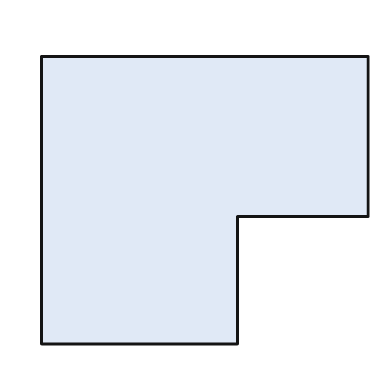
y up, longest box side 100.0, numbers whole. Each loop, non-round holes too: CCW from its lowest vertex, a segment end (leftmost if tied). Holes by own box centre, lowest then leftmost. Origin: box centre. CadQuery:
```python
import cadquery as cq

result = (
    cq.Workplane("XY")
    .moveTo(-50.0, -44.0)
    .lineTo(10.0, -44.0)
    .lineTo(10.0, -5.0)
    .lineTo(50.0, -5.0)
    .lineTo(50.0, 44.0)
    .lineTo(-50.0, 44.0)
    .close()
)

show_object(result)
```